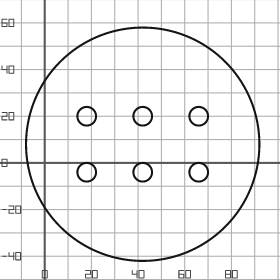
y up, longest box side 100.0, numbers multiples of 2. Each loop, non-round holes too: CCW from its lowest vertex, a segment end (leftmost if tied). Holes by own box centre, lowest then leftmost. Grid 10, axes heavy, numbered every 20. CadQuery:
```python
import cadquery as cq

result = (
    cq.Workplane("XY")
    .moveTo(42.0, 8.0)
    .circle(50.0)
    .moveTo(18.0, -4.0)
    .circle(4.0)
    .moveTo(42.0, -4.0)
    .circle(4.0)
    .moveTo(66.0, -4.0)
    .circle(4.0)
    .moveTo(18.0, 20.0)
    .circle(4.0)
    .moveTo(42.0, 20.0)
    .circle(4.0)
    .moveTo(66.0, 20.0)
    .circle(4.0)
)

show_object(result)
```